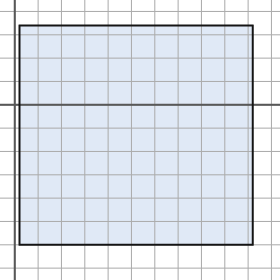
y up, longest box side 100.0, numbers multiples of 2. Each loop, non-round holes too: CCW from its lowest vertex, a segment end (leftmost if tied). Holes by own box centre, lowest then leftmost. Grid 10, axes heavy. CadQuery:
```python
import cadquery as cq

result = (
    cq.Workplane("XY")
    .moveTo(2.0, -60.0)
    .lineTo(102.0, -60.0)
    .lineTo(102.0, 34.0)
    .lineTo(2.0, 34.0)
    .close()
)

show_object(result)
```